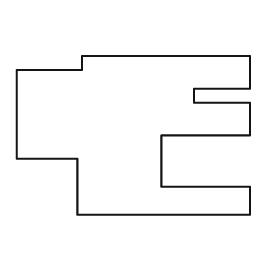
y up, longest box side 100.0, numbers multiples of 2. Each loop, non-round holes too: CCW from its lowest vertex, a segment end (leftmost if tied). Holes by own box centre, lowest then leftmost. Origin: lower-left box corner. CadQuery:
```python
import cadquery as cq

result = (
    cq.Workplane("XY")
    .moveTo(26.0, 0.0)
    .lineTo(100.0, 0.0)
    .lineTo(100.0, 12.0)
    .lineTo(62.0, 12.0)
    .lineTo(62.0, 34.0)
    .lineTo(100.0, 34.0)
    .lineTo(100.0, 48.0)
    .lineTo(76.0, 48.0)
    .lineTo(76.0, 54.0)
    .lineTo(100.0, 54.0)
    .lineTo(100.0, 68.0)
    .lineTo(28.0, 68.0)
    .lineTo(28.0, 62.0)
    .lineTo(0.0, 62.0)
    .lineTo(0.0, 24.0)
    .lineTo(26.0, 24.0)
    .close()
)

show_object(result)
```